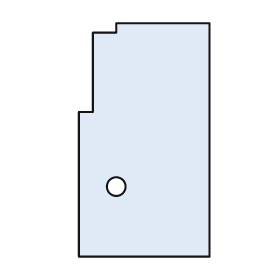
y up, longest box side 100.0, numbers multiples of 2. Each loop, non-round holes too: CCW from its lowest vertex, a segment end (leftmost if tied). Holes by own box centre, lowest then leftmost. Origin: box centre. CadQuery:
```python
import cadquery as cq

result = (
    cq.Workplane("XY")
    .moveTo(-28.0, -50.0)
    .lineTo(28.0, -50.0)
    .lineTo(28.0, 50.0)
    .lineTo(-12.0, 50.0)
    .lineTo(-12.0, 46.0)
    .lineTo(-22.0, 46.0)
    .lineTo(-22.0, 12.0)
    .lineTo(-28.0, 12.0)
    .close()
    .moveTo(-12.0, -20.0)
    .circle(4.0)
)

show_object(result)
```